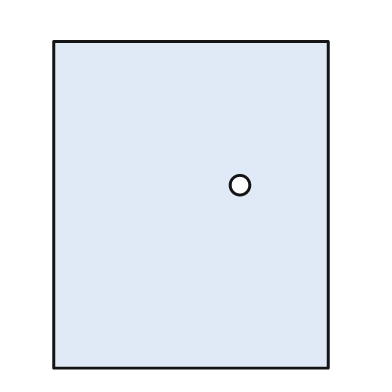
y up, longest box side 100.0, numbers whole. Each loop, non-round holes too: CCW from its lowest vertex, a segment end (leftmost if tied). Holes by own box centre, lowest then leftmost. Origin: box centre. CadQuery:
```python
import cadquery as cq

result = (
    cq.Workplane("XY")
    .moveTo(-42.0, -50.0)
    .lineTo(42.0, -50.0)
    .lineTo(42.0, 50.0)
    .lineTo(-42.0, 50.0)
    .close()
    .moveTo(15.0, 6.0)
    .circle(3.0)
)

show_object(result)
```